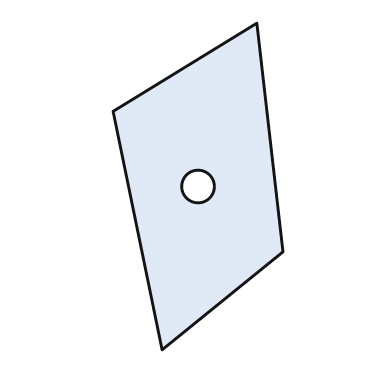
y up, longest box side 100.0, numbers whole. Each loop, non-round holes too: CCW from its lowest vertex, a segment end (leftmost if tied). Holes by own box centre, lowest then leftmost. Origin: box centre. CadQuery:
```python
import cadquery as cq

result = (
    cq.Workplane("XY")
    .moveTo(-11.0, -50.0)
    .lineTo(26.0, -20.0)
    .lineTo(18.0, 50.0)
    .lineTo(-26.0, 23.0)
    .close()
    .moveTo(0.0, 0.0)
    .circle(5.0)
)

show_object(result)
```